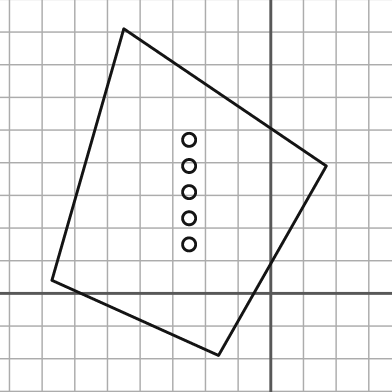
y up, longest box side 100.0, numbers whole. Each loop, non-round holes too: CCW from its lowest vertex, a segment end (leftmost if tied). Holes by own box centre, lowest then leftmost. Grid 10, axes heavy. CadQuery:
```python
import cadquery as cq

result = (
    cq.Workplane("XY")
    .moveTo(-16.0, -19.0)
    .lineTo(17.0, 39.0)
    .lineTo(-45.0, 81.0)
    .lineTo(-67.0, 4.0)
    .close()
    .moveTo(-25.0, 15.0)
    .circle(2.0)
    .moveTo(-25.0, 23.0)
    .circle(2.0)
    .moveTo(-25.0, 31.0)
    .circle(2.0)
    .moveTo(-25.0, 39.0)
    .circle(2.0)
    .moveTo(-25.0, 47.0)
    .circle(2.0)
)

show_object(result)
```